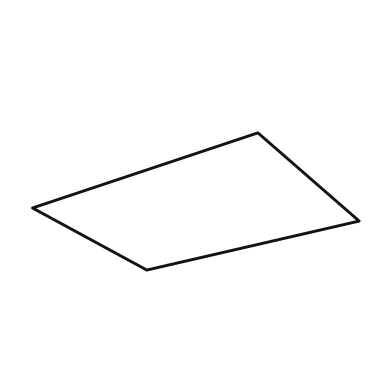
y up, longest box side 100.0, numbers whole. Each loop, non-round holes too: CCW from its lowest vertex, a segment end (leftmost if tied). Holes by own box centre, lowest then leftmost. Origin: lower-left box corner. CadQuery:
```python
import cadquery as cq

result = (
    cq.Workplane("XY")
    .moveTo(35.0, 0.0)
    .lineTo(100.0, 15.0)
    .lineTo(69.0, 42.0)
    .lineTo(0.0, 19.0)
    .close()
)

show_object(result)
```